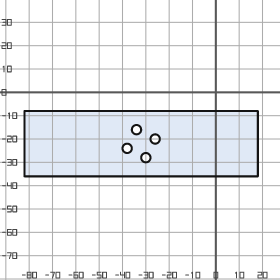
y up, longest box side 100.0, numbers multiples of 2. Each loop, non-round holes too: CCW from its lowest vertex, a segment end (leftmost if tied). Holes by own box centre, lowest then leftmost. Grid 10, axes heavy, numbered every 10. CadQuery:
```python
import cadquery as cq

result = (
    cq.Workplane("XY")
    .moveTo(-82.0, -36.0)
    .lineTo(18.0, -36.0)
    .lineTo(18.0, -8.0)
    .lineTo(-82.0, -8.0)
    .close()
    .moveTo(-30.0, -28.0)
    .circle(2.0)
    .moveTo(-38.0, -24.0)
    .circle(2.0)
    .moveTo(-26.0, -20.0)
    .circle(2.0)
    .moveTo(-34.0, -16.0)
    .circle(2.0)
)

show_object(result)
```